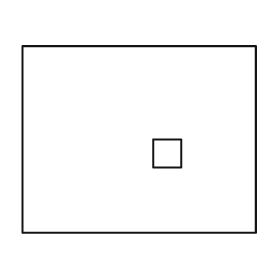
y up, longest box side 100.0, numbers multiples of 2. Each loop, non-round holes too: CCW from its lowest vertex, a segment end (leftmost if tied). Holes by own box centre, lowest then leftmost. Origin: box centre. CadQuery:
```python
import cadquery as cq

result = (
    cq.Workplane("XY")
    .moveTo(-50.0, -40.0)
    .lineTo(50.0, -40.0)
    .lineTo(50.0, 40.0)
    .lineTo(-50.0, 40.0)
    .close()
    .moveTo(6.0, -12.0)
    .lineTo(18.0, -12.0)
    .lineTo(18.0, 0.0)
    .lineTo(6.0, 0.0)
    .close()
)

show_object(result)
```